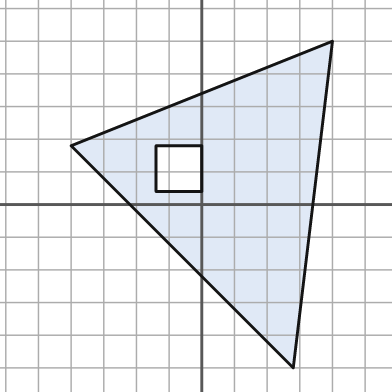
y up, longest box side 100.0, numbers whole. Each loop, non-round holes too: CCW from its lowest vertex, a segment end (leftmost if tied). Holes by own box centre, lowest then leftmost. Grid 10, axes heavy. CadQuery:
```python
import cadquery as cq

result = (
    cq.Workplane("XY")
    .moveTo(28.0, -50.0)
    .lineTo(40.0, 50.0)
    .lineTo(-40.0, 18.0)
    .close()
    .moveTo(-14.0, 4.0)
    .lineTo(0.0, 4.0)
    .lineTo(0.0, 18.0)
    .lineTo(-14.0, 18.0)
    .close()
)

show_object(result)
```